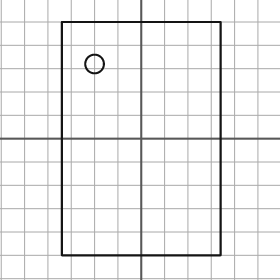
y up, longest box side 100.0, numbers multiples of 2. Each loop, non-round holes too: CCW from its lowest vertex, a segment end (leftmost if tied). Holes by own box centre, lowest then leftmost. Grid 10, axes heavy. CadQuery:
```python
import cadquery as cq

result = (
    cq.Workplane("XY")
    .moveTo(-34.0, -50.0)
    .lineTo(34.0, -50.0)
    .lineTo(34.0, 50.0)
    .lineTo(-34.0, 50.0)
    .close()
    .moveTo(-20.0, 32.0)
    .circle(4.0)
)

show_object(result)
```